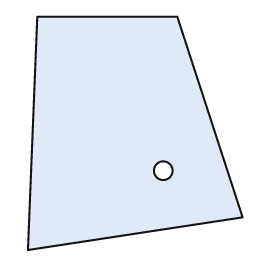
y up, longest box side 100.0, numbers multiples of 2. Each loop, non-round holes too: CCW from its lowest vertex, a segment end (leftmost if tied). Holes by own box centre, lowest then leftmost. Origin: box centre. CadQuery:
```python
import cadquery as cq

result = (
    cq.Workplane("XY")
    .moveTo(-46.0, -50.0)
    .lineTo(46.0, -36.0)
    .lineTo(18.0, 50.0)
    .lineTo(-42.0, 50.0)
    .close()
    .moveTo(12.0, -16.0)
    .circle(4.0)
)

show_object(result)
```